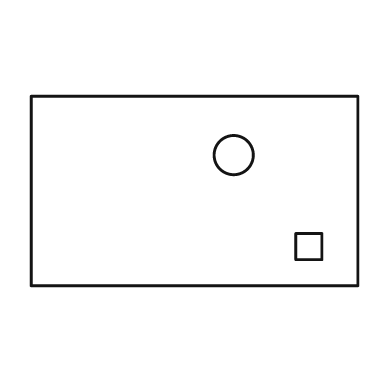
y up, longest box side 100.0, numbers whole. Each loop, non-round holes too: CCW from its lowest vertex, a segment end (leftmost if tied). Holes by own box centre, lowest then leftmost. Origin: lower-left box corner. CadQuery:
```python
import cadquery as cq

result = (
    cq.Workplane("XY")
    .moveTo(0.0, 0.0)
    .lineTo(100.0, 0.0)
    .lineTo(100.0, 58.0)
    .lineTo(0.0, 58.0)
    .close()
    .moveTo(81.0, 8.0)
    .lineTo(89.0, 8.0)
    .lineTo(89.0, 16.0)
    .lineTo(81.0, 16.0)
    .close()
    .moveTo(62.0, 40.0)
    .circle(6.0)
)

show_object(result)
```